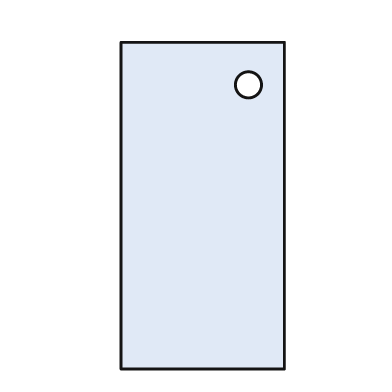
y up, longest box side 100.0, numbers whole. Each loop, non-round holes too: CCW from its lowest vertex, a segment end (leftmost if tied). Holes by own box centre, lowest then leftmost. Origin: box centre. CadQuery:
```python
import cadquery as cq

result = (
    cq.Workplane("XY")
    .moveTo(-25.0, -50.0)
    .lineTo(25.0, -50.0)
    .lineTo(25.0, 50.0)
    .lineTo(-25.0, 50.0)
    .close()
    .moveTo(14.0, 37.0)
    .circle(4.0)
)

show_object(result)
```